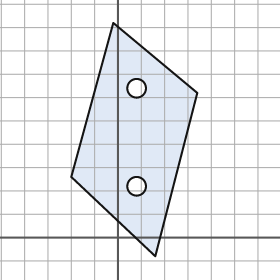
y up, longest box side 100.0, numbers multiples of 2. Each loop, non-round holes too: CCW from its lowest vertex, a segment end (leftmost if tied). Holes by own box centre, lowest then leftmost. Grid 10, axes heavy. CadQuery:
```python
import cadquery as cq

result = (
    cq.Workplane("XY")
    .moveTo(16.0, -8.0)
    .lineTo(34.0, 62.0)
    .lineTo(-2.0, 92.0)
    .lineTo(-20.0, 26.0)
    .close()
    .moveTo(8.0, 22.0)
    .circle(4.0)
    .moveTo(8.0, 64.0)
    .circle(4.0)
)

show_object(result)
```